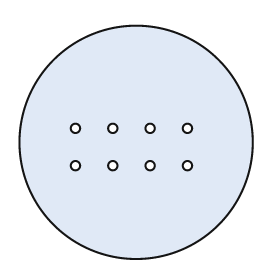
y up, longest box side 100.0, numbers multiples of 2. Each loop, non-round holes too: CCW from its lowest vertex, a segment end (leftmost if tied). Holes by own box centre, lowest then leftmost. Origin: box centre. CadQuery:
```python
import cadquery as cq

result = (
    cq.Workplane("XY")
    .moveTo(0.0, 0.0)
    .circle(50.0)
    .moveTo(-26.0, -10.0)
    .circle(2.0)
    .moveTo(-10.0, -10.0)
    .circle(2.0)
    .moveTo(6.0, -10.0)
    .circle(2.0)
    .moveTo(22.0, -10.0)
    .circle(2.0)
    .moveTo(-26.0, 6.0)
    .circle(2.0)
    .moveTo(-10.0, 6.0)
    .circle(2.0)
    .moveTo(6.0, 6.0)
    .circle(2.0)
    .moveTo(22.0, 6.0)
    .circle(2.0)
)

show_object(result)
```